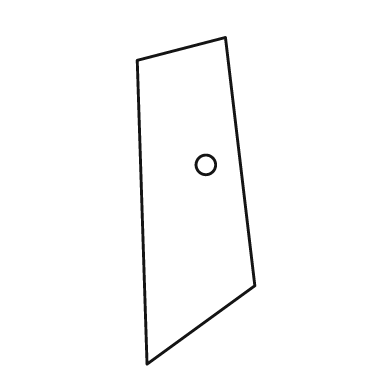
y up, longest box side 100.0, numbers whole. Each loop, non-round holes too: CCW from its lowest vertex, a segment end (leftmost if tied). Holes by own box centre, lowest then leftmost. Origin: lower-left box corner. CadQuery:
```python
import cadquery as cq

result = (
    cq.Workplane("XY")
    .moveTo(3.0, 0.0)
    .lineTo(36.0, 24.0)
    .lineTo(27.0, 100.0)
    .lineTo(0.0, 93.0)
    .close()
    .moveTo(21.0, 61.0)
    .circle(3.0)
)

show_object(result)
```